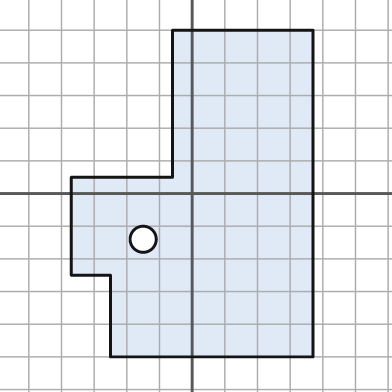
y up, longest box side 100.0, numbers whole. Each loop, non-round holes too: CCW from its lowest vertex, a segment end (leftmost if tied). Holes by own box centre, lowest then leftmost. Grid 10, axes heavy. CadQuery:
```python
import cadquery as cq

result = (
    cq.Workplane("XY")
    .moveTo(-25.0, -50.0)
    .lineTo(37.0, -50.0)
    .lineTo(37.0, 50.0)
    .lineTo(-6.0, 50.0)
    .lineTo(-6.0, 5.0)
    .lineTo(-37.0, 5.0)
    .lineTo(-37.0, -25.0)
    .lineTo(-25.0, -25.0)
    .close()
    .moveTo(-15.0, -14.0)
    .circle(4.0)
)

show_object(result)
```